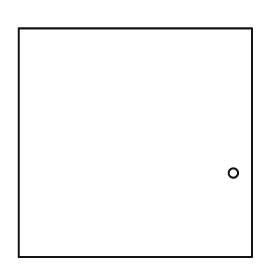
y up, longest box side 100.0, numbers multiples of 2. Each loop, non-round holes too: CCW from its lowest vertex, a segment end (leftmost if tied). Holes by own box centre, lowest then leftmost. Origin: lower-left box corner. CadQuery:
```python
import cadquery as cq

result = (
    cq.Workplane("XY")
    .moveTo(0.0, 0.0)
    .lineTo(100.0, 0.0)
    .lineTo(100.0, 98.0)
    .lineTo(0.0, 98.0)
    .close()
    .moveTo(92.0, 36.0)
    .circle(2.0)
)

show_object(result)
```